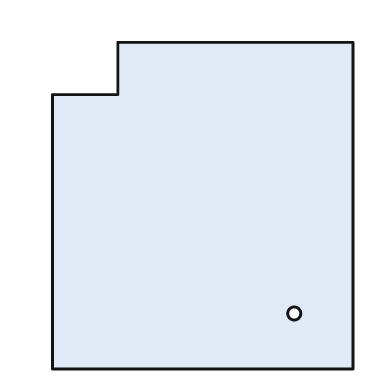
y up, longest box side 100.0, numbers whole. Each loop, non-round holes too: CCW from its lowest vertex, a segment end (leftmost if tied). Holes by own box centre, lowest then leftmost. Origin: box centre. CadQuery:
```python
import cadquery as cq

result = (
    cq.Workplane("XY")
    .moveTo(-46.0, -50.0)
    .lineTo(46.0, -50.0)
    .lineTo(46.0, 50.0)
    .lineTo(-26.0, 50.0)
    .lineTo(-26.0, 34.0)
    .lineTo(-46.0, 34.0)
    .close()
    .moveTo(28.0, -33.0)
    .circle(2.0)
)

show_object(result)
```